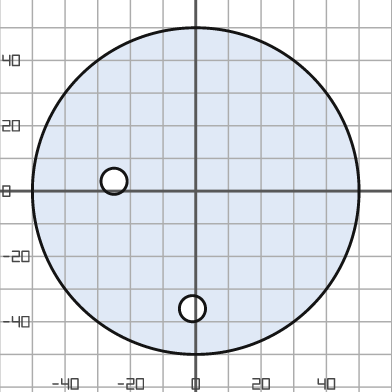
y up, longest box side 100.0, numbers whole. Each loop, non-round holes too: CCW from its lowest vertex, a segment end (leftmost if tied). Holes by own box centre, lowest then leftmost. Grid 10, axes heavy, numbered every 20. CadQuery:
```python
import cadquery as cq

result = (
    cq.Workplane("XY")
    .moveTo(0.0, 0.0)
    .circle(50.0)
    .moveTo(-1.0, -36.0)
    .circle(4.0)
    .moveTo(-25.0, 3.0)
    .circle(4.0)
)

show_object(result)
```